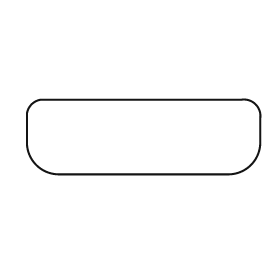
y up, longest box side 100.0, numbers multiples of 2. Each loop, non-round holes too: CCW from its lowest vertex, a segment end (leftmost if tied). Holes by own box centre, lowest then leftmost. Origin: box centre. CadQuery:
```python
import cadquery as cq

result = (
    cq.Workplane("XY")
    .moveTo(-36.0, -16.0)
    .lineTo(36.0, -16.0)
    .threePointArc((46.0, -12.0), (50.0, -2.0))
    .lineTo(50.0, 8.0)
    .threePointArc((48.0, 14.0), (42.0, 16.0))
    .lineTo(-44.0, 16.0)
    .threePointArc((-48.0, 14.0), (-50.0, 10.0))
    .lineTo(-50.0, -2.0)
    .threePointArc((-46.0, -12.0), (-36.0, -16.0))
    .close()
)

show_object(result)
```